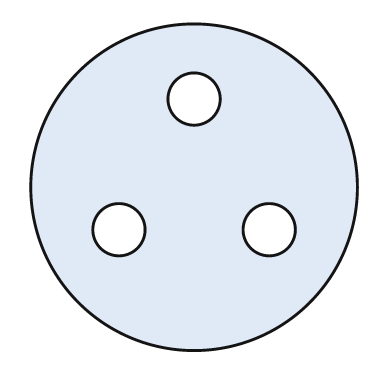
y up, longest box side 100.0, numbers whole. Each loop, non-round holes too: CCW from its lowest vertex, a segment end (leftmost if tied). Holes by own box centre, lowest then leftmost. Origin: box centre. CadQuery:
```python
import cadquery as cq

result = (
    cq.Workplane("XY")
    .moveTo(0.0, 0.0)
    .circle(50.0)
    .moveTo(-23.0, -13.0)
    .circle(8.0)
    .moveTo(23.0, -13.0)
    .circle(8.0)
    .moveTo(0.0, 27.0)
    .circle(8.0)
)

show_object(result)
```